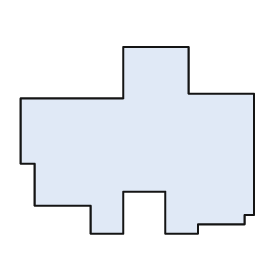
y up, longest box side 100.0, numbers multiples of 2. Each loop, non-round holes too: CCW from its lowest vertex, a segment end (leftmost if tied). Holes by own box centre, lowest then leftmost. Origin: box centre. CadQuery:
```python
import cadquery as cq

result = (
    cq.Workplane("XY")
    .moveTo(-20.0, -40.0)
    .lineTo(-6.0, -40.0)
    .lineTo(-6.0, -22.0)
    .lineTo(12.0, -22.0)
    .lineTo(12.0, -40.0)
    .lineTo(26.0, -40.0)
    .lineTo(26.0, -36.0)
    .lineTo(46.0, -36.0)
    .lineTo(46.0, -32.0)
    .lineTo(50.0, -32.0)
    .lineTo(50.0, 20.0)
    .lineTo(22.0, 20.0)
    .lineTo(22.0, 40.0)
    .lineTo(-6.0, 40.0)
    .lineTo(-6.0, 18.0)
    .lineTo(-50.0, 18.0)
    .lineTo(-50.0, -10.0)
    .lineTo(-44.0, -10.0)
    .lineTo(-44.0, -28.0)
    .lineTo(-20.0, -28.0)
    .close()
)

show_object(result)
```